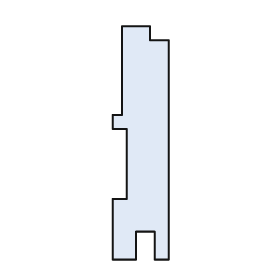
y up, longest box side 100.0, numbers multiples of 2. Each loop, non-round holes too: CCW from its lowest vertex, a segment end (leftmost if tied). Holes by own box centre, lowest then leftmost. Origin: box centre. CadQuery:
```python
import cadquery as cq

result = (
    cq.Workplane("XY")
    .moveTo(-12.0, -50.0)
    .lineTo(-2.0, -50.0)
    .lineTo(-2.0, -38.0)
    .lineTo(6.0, -38.0)
    .lineTo(6.0, -50.0)
    .lineTo(12.0, -50.0)
    .lineTo(12.0, 44.0)
    .lineTo(4.0, 44.0)
    .lineTo(4.0, 50.0)
    .lineTo(-8.0, 50.0)
    .lineTo(-8.0, 12.0)
    .lineTo(-12.0, 12.0)
    .lineTo(-12.0, 6.0)
    .lineTo(-6.0, 6.0)
    .lineTo(-6.0, -24.0)
    .lineTo(-12.0, -24.0)
    .close()
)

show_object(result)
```